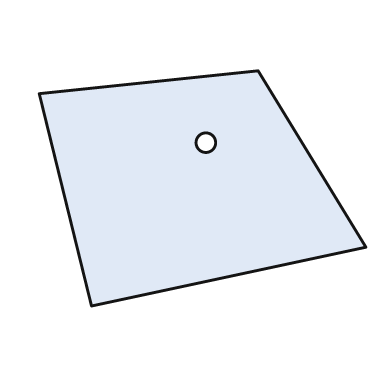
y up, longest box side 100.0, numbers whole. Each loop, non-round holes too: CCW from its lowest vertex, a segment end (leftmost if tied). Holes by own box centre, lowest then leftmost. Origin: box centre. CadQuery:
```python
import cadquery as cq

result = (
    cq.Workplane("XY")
    .moveTo(-34.0, -36.0)
    .lineTo(50.0, -18.0)
    .lineTo(17.0, 36.0)
    .lineTo(-50.0, 29.0)
    .close()
    .moveTo(1.0, 14.0)
    .circle(3.0)
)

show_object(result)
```